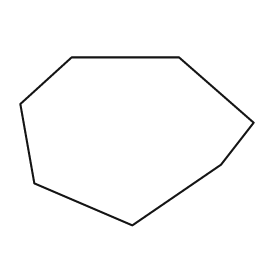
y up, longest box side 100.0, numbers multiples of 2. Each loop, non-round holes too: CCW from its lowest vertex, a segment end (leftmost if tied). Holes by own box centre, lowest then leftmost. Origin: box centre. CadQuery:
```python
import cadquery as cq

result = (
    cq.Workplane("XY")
    .moveTo(-2.0, -36.0)
    .lineTo(36.0, -10.0)
    .lineTo(50.0, 8.0)
    .lineTo(18.0, 36.0)
    .lineTo(-28.0, 36.0)
    .lineTo(-50.0, 16.0)
    .lineTo(-44.0, -18.0)
    .close()
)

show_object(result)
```